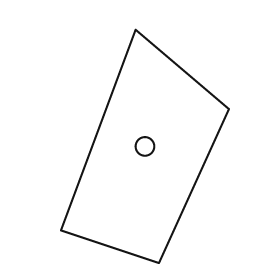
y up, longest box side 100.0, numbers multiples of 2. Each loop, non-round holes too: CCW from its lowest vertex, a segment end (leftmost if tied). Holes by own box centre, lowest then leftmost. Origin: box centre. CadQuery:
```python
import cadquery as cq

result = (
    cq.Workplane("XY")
    .moveTo(6.0, -50.0)
    .lineTo(36.0, 16.0)
    .lineTo(-4.0, 50.0)
    .lineTo(-36.0, -36.0)
    .close()
    .moveTo(0.0, 0.0)
    .circle(4.0)
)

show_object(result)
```